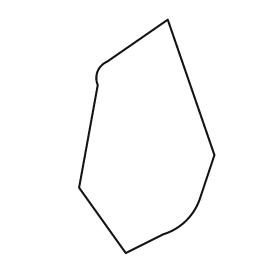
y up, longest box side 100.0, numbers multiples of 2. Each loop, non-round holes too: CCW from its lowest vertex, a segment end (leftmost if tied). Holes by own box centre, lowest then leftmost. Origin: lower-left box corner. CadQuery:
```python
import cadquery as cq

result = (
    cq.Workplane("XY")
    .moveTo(20.0, 0.0)
    .lineTo(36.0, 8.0)
    .threePointArc((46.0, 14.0), (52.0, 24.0))
    .lineTo(58.0, 42.0)
    .lineTo(38.0, 100.0)
    .lineTo(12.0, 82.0)
    .threePointArc((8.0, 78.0), (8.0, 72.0))
    .lineTo(0.0, 28.0)
    .close()
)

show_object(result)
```